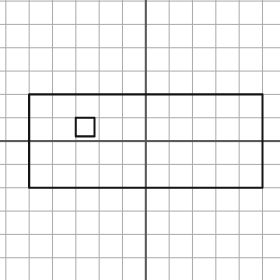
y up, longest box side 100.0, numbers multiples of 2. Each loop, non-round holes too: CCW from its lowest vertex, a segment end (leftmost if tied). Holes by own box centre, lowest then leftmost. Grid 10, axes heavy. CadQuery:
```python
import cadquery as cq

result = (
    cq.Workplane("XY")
    .moveTo(-50.0, -20.0)
    .lineTo(50.0, -20.0)
    .lineTo(50.0, 20.0)
    .lineTo(-50.0, 20.0)
    .close()
    .moveTo(-30.0, 2.0)
    .lineTo(-22.0, 2.0)
    .lineTo(-22.0, 10.0)
    .lineTo(-30.0, 10.0)
    .close()
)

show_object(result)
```